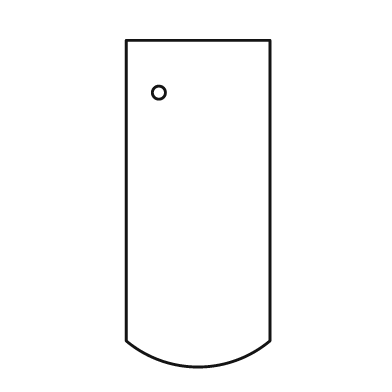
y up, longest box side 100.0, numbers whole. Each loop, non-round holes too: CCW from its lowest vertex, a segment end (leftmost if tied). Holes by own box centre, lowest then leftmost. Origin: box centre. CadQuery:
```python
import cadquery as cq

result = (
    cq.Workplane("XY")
    .moveTo(-22.0, -42.0)
    .threePointArc((0.0, -50.0), (22.0, -42.0))
    .lineTo(22.0, 50.0)
    .lineTo(-22.0, 50.0)
    .close()
    .moveTo(-12.0, 34.0)
    .circle(2.0)
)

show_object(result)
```